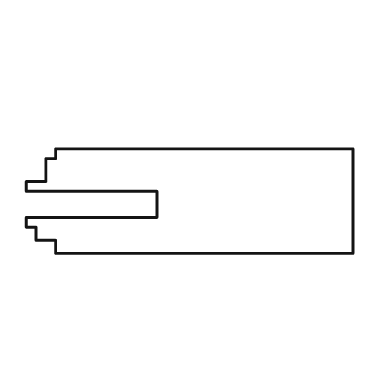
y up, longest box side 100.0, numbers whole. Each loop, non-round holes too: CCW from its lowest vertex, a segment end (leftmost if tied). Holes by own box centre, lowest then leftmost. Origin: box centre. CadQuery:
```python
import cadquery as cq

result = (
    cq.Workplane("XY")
    .moveTo(-41.0, -16.0)
    .lineTo(50.0, -16.0)
    .lineTo(50.0, 16.0)
    .lineTo(-41.0, 16.0)
    .lineTo(-41.0, 13.0)
    .lineTo(-44.0, 13.0)
    .lineTo(-44.0, 6.0)
    .lineTo(-50.0, 6.0)
    .lineTo(-50.0, 3.0)
    .lineTo(-10.0, 3.0)
    .lineTo(-10.0, -5.0)
    .lineTo(-50.0, -5.0)
    .lineTo(-50.0, -8.0)
    .lineTo(-47.0, -8.0)
    .lineTo(-47.0, -12.0)
    .lineTo(-41.0, -12.0)
    .close()
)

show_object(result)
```